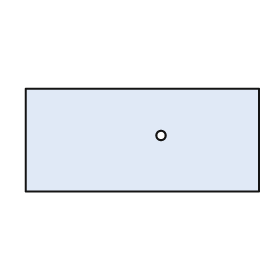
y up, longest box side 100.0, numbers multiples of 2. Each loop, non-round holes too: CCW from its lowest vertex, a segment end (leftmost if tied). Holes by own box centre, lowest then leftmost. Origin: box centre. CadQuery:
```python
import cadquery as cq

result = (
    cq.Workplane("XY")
    .moveTo(-50.0, -22.0)
    .lineTo(50.0, -22.0)
    .lineTo(50.0, 22.0)
    .lineTo(-50.0, 22.0)
    .close()
    .moveTo(8.0, 2.0)
    .circle(2.0)
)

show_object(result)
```